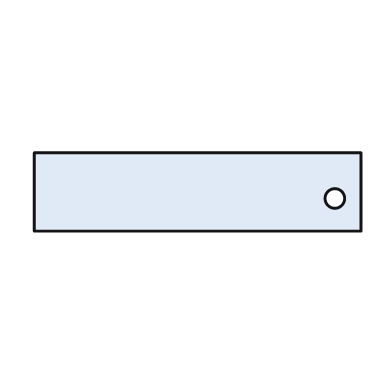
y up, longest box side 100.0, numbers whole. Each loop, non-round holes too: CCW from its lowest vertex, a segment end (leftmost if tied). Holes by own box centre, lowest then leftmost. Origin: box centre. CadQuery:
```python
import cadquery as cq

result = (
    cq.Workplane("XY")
    .moveTo(-50.0, -12.0)
    .lineTo(50.0, -12.0)
    .lineTo(50.0, 12.0)
    .lineTo(-50.0, 12.0)
    .close()
    .moveTo(42.0, -2.0)
    .circle(3.0)
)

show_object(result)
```